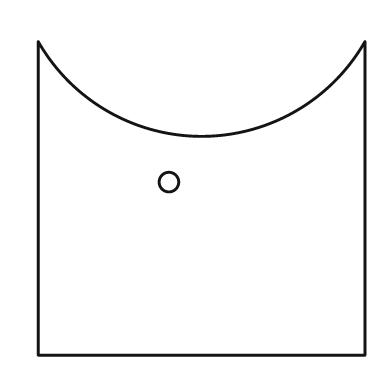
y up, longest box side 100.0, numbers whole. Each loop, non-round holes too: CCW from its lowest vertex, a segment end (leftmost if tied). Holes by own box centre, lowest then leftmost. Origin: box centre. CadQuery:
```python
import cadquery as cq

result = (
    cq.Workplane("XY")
    .moveTo(-50.0, -48.0)
    .lineTo(50.0, -48.0)
    .lineTo(50.0, 48.0)
    .threePointArc((0.0, 19.0), (-50.0, 48.0))
    .close()
    .moveTo(-10.0, 5.0)
    .circle(3.0)
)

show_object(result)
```